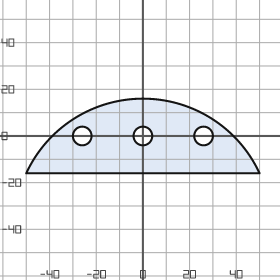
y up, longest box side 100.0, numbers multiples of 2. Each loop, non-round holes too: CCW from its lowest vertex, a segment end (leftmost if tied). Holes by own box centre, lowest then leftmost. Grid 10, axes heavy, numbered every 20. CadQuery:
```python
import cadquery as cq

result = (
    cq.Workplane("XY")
    .moveTo(-50.0, -16.0)
    .lineTo(50.0, -16.0)
    .threePointArc((0.0, 16.0), (-50.0, -16.0))
    .close()
    .moveTo(-26.0, 0.0)
    .circle(4.0)
    .moveTo(0.0, 0.0)
    .circle(4.0)
    .moveTo(26.0, 0.0)
    .circle(4.0)
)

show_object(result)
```